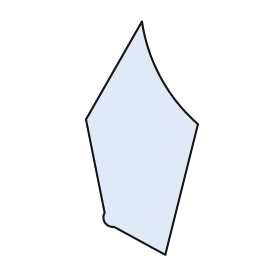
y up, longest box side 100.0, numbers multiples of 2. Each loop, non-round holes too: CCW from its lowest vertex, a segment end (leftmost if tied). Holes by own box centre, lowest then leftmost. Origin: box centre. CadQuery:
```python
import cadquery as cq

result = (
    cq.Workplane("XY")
    .moveTo(10.0, -50.0)
    .lineTo(24.0, 6.0)
    .threePointArc((8.0, 26.0), (0.0, 50.0))
    .lineTo(-24.0, 8.0)
    .lineTo(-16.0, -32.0)
    .threePointArc((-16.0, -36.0), (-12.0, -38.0))
    .close()
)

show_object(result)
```